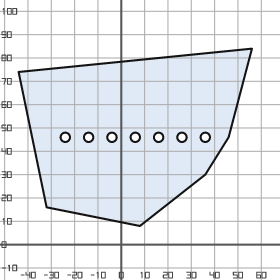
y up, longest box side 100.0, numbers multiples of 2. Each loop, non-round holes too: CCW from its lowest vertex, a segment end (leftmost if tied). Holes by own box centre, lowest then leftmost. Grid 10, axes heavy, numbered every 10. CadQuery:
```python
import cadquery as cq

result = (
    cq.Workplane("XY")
    .moveTo(8.0, 8.0)
    .lineTo(36.0, 30.0)
    .lineTo(46.0, 46.0)
    .lineTo(56.0, 84.0)
    .lineTo(-44.0, 74.0)
    .lineTo(-32.0, 16.0)
    .close()
    .moveTo(-24.0, 46.0)
    .circle(2.0)
    .moveTo(-14.0, 46.0)
    .circle(2.0)
    .moveTo(-4.0, 46.0)
    .circle(2.0)
    .moveTo(6.0, 46.0)
    .circle(2.0)
    .moveTo(16.0, 46.0)
    .circle(2.0)
    .moveTo(26.0, 46.0)
    .circle(2.0)
    .moveTo(36.0, 46.0)
    .circle(2.0)
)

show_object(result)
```